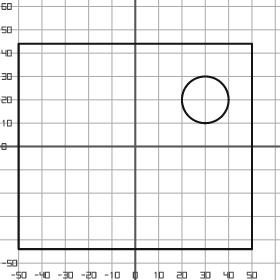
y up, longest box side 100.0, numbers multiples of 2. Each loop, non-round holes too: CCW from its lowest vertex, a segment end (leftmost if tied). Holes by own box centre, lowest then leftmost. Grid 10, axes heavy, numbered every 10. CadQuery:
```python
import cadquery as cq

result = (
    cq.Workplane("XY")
    .moveTo(-50.0, -44.0)
    .lineTo(50.0, -44.0)
    .lineTo(50.0, 44.0)
    .lineTo(-50.0, 44.0)
    .close()
    .moveTo(30.0, 20.0)
    .circle(10.0)
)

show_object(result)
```